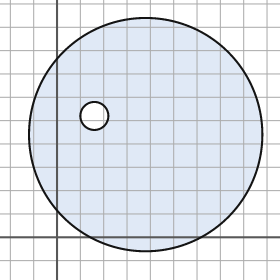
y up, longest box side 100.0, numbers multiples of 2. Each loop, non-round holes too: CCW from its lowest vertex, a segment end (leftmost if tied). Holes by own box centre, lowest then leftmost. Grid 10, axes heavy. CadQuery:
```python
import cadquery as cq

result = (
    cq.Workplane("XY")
    .moveTo(38.0, 44.0)
    .circle(50.0)
    .moveTo(16.0, 52.0)
    .circle(6.0)
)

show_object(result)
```